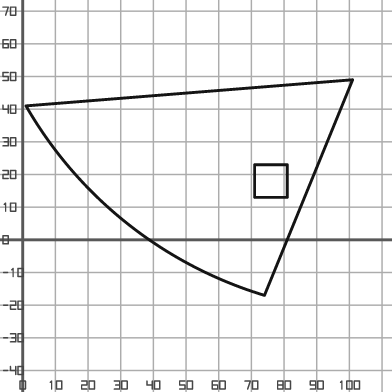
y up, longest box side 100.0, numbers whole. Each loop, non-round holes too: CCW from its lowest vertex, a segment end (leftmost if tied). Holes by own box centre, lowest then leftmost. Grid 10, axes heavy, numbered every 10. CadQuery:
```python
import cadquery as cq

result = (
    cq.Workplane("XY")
    .moveTo(74.0, -17.0)
    .lineTo(101.0, 49.0)
    .lineTo(1.0, 41.0)
    .threePointArc((32.0, 5.0), (74.0, -17.0))
    .close()
    .moveTo(71.0, 13.0)
    .lineTo(81.0, 13.0)
    .lineTo(81.0, 23.0)
    .lineTo(71.0, 23.0)
    .close()
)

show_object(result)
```